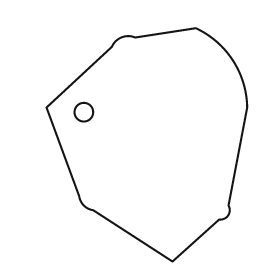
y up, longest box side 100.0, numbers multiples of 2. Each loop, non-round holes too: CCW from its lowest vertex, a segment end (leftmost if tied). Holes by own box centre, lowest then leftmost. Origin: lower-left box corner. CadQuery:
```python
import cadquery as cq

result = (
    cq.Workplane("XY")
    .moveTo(54.0, 0.0)
    .lineTo(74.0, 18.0)
    .threePointArc((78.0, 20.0), (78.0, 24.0))
    .lineTo(86.0, 66.0)
    .threePointArc((80.0, 86.0), (64.0, 100.0))
    .lineTo(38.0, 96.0)
    .threePointArc((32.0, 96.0), (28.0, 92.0))
    .lineTo(0.0, 66.0)
    .lineTo(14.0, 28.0)
    .threePointArc((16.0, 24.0), (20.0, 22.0))
    .close()
    .moveTo(16.0, 64.0)
    .circle(4.0)
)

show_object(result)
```